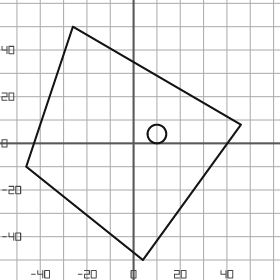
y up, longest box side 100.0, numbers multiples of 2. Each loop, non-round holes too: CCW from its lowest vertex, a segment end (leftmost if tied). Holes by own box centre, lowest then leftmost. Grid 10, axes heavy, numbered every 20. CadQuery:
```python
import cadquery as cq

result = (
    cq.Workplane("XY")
    .moveTo(4.0, -50.0)
    .lineTo(46.0, 8.0)
    .lineTo(-26.0, 50.0)
    .lineTo(-46.0, -10.0)
    .close()
    .moveTo(10.0, 4.0)
    .circle(4.0)
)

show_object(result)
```